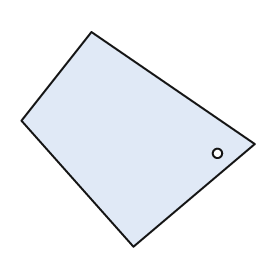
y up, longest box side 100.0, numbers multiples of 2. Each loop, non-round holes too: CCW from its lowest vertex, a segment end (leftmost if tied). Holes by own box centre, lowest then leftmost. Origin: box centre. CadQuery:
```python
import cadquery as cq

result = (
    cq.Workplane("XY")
    .moveTo(-2.0, -46.0)
    .lineTo(50.0, -2.0)
    .lineTo(-20.0, 46.0)
    .lineTo(-50.0, 8.0)
    .close()
    .moveTo(34.0, -6.0)
    .circle(2.0)
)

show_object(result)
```